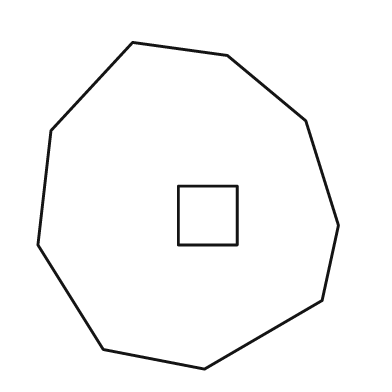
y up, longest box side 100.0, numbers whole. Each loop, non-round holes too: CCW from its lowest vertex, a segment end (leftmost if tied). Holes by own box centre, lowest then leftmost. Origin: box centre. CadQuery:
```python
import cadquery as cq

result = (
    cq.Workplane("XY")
    .moveTo(5.0, -50.0)
    .lineTo(41.0, -29.0)
    .lineTo(46.0, -6.0)
    .lineTo(36.0, 26.0)
    .lineTo(12.0, 46.0)
    .lineTo(-17.0, 50.0)
    .lineTo(-42.0, 23.0)
    .lineTo(-46.0, -12.0)
    .lineTo(-26.0, -44.0)
    .close()
    .moveTo(-3.0, -12.0)
    .lineTo(15.0, -12.0)
    .lineTo(15.0, 6.0)
    .lineTo(-3.0, 6.0)
    .close()
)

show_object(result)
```